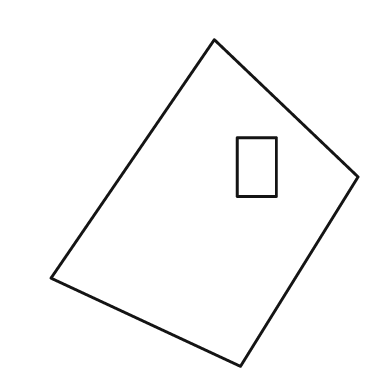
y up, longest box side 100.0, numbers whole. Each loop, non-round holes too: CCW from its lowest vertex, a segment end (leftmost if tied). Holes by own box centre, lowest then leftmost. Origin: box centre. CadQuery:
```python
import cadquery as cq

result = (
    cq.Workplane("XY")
    .moveTo(11.0, -50.0)
    .lineTo(47.0, 8.0)
    .lineTo(3.0, 50.0)
    .lineTo(-47.0, -23.0)
    .close()
    .moveTo(10.0, 2.0)
    .lineTo(22.0, 2.0)
    .lineTo(22.0, 20.0)
    .lineTo(10.0, 20.0)
    .close()
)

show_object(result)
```